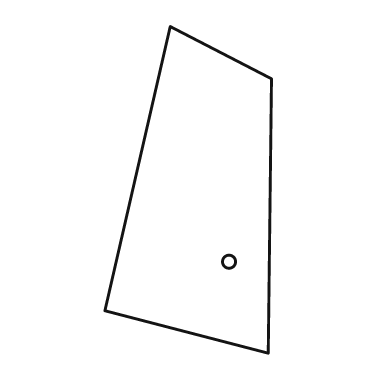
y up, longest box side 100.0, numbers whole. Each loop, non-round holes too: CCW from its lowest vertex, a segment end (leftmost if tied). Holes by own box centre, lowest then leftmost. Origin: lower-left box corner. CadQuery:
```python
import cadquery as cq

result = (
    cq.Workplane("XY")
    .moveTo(50.0, 0.0)
    .lineTo(51.0, 84.0)
    .lineTo(20.0, 100.0)
    .lineTo(0.0, 13.0)
    .close()
    .moveTo(38.0, 28.0)
    .circle(2.0)
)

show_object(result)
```